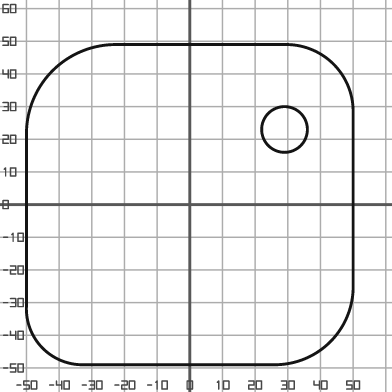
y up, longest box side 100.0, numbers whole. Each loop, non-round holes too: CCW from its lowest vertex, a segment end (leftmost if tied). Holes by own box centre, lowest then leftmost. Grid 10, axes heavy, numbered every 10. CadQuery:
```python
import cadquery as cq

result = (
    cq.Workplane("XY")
    .moveTo(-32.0, -49.0)
    .lineTo(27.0, -49.0)
    .threePointArc((43.0, -42.0), (50.0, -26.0))
    .lineTo(50.0, 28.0)
    .threePointArc((44.0, 43.0), (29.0, 49.0))
    .lineTo(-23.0, 49.0)
    .threePointArc((-42.0, 41.0), (-50.0, 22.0))
    .lineTo(-50.0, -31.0)
    .threePointArc((-45.0, -44.0), (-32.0, -49.0))
    .close()
    .moveTo(29.0, 23.0)
    .circle(7.0)
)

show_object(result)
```